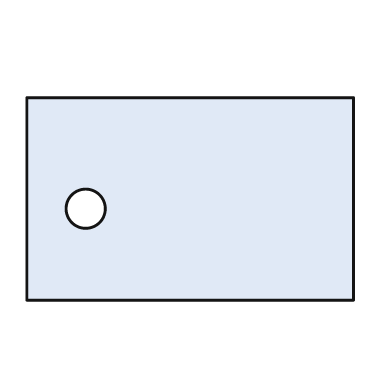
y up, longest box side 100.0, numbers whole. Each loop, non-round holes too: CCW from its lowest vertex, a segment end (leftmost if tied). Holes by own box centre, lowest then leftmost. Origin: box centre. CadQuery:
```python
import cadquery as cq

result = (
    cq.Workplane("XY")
    .moveTo(-50.0, -31.0)
    .lineTo(50.0, -31.0)
    .lineTo(50.0, 31.0)
    .lineTo(-50.0, 31.0)
    .close()
    .moveTo(-32.0, -3.0)
    .circle(6.0)
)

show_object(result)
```